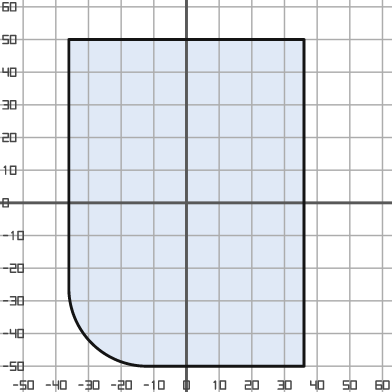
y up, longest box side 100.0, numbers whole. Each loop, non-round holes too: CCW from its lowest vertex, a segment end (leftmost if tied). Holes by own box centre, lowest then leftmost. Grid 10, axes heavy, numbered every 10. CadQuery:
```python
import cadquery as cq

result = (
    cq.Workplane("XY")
    .moveTo(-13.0, -50.0)
    .lineTo(36.0, -50.0)
    .lineTo(36.0, 50.0)
    .lineTo(-36.0, 50.0)
    .lineTo(-36.0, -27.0)
    .threePointArc((-29.0, -43.0), (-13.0, -50.0))
    .close()
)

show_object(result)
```